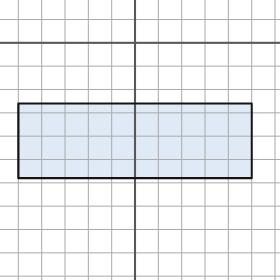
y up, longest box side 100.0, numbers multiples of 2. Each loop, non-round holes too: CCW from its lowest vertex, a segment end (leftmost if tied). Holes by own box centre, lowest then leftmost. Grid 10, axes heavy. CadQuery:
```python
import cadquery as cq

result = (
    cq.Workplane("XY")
    .moveTo(-50.0, -58.0)
    .lineTo(50.0, -58.0)
    .lineTo(50.0, -26.0)
    .lineTo(-50.0, -26.0)
    .close()
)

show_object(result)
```